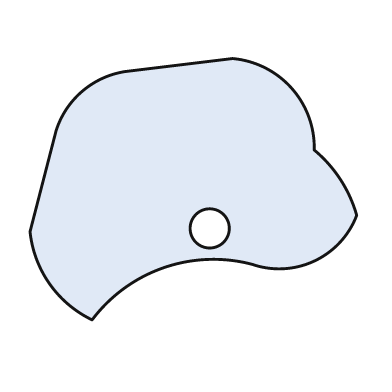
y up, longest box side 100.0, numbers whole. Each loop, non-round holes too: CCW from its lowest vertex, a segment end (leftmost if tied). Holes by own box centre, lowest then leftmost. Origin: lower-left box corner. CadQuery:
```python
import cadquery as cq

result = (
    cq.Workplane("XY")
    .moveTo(19.0, 0.0)
    .threePointArc((41.0, 16.0), (68.0, 17.0))
    .threePointArc((87.0, 18.0), (100.0, 32.0))
    .threePointArc((95.0, 43.0), (87.0, 52.0))
    .threePointArc((80.0, 71.0), (62.0, 80.0))
    .lineTo(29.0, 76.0)
    .threePointArc((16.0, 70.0), (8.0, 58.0))
    .lineTo(0.0, 27.0)
    .threePointArc((6.0, 11.0), (19.0, 0.0))
    .close()
    .moveTo(55.0, 28.0)
    .circle(6.0)
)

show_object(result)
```